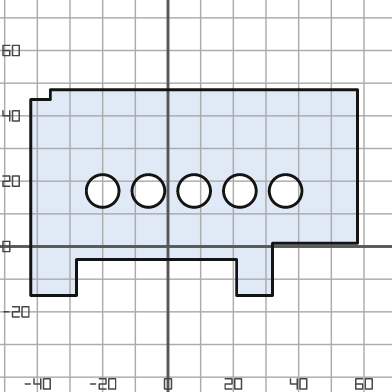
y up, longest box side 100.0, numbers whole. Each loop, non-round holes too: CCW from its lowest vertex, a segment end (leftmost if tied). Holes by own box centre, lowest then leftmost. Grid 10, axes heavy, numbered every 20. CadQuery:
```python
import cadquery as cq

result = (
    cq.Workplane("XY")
    .moveTo(-42.0, -15.0)
    .lineTo(-28.0, -15.0)
    .lineTo(-28.0, -4.0)
    .lineTo(21.0, -4.0)
    .lineTo(21.0, -15.0)
    .lineTo(32.0, -15.0)
    .lineTo(32.0, 1.0)
    .lineTo(58.0, 1.0)
    .lineTo(58.0, 48.0)
    .lineTo(-36.0, 48.0)
    .lineTo(-36.0, 45.0)
    .lineTo(-42.0, 45.0)
    .close()
    .moveTo(-20.0, 17.0)
    .circle(5.0)
    .moveTo(-6.0, 17.0)
    .circle(5.0)
    .moveTo(8.0, 17.0)
    .circle(5.0)
    .moveTo(22.0, 17.0)
    .circle(5.0)
    .moveTo(36.0, 17.0)
    .circle(5.0)
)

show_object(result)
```